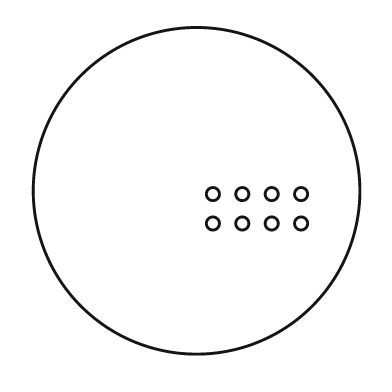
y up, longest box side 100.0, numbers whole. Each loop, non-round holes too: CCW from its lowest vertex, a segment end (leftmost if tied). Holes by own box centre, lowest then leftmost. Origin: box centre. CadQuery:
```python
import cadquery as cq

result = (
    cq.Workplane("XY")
    .moveTo(0.0, 0.0)
    .circle(50.0)
    .moveTo(5.0, -10.0)
    .circle(2.0)
    .moveTo(14.0, -10.0)
    .circle(2.0)
    .moveTo(23.0, -10.0)
    .circle(2.0)
    .moveTo(32.0, -10.0)
    .circle(2.0)
    .moveTo(5.0, -1.0)
    .circle(2.0)
    .moveTo(14.0, -1.0)
    .circle(2.0)
    .moveTo(23.0, -1.0)
    .circle(2.0)
    .moveTo(32.0, -1.0)
    .circle(2.0)
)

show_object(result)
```